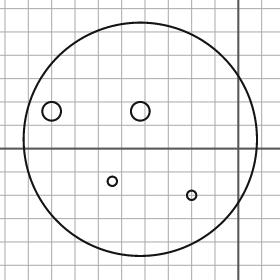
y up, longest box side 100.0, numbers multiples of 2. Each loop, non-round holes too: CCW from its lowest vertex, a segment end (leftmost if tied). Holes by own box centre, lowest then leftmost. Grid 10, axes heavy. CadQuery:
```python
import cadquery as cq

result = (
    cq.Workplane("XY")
    .moveTo(-42.0, 4.0)
    .circle(50.0)
    .moveTo(-20.0, -20.0)
    .circle(2.0)
    .moveTo(-54.0, -14.0)
    .circle(2.0)
    .moveTo(-80.0, 16.0)
    .circle(4.0)
    .moveTo(-42.0, 16.0)
    .circle(4.0)
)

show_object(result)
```